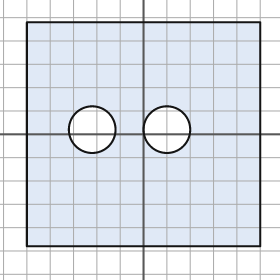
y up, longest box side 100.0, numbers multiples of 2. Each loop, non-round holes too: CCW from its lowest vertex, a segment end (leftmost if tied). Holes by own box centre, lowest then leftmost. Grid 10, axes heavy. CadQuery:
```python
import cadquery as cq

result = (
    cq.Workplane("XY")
    .moveTo(-50.0, -48.0)
    .lineTo(50.0, -48.0)
    .lineTo(50.0, 48.0)
    .lineTo(-50.0, 48.0)
    .close()
    .moveTo(-22.0, 2.0)
    .circle(10.0)
    .moveTo(10.0, 2.0)
    .circle(10.0)
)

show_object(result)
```